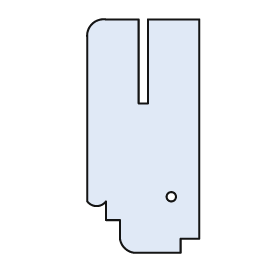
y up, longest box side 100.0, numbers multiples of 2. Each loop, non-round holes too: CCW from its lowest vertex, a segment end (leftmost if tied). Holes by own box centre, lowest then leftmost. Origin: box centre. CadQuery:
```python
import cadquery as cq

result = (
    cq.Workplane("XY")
    .moveTo(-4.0, -50.0)
    .lineTo(16.0, -50.0)
    .lineTo(16.0, -44.0)
    .lineTo(24.0, -44.0)
    .lineTo(24.0, 50.0)
    .lineTo(2.0, 50.0)
    .lineTo(2.0, 14.0)
    .lineTo(-2.0, 14.0)
    .lineTo(-2.0, 50.0)
    .lineTo(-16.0, 50.0)
    .threePointArc((-22.0, 48.0), (-24.0, 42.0))
    .lineTo(-24.0, -28.0)
    .threePointArc((-20.0, -30.0), (-16.0, -28.0))
    .lineTo(-16.0, -36.0)
    .lineTo(-10.0, -36.0)
    .lineTo(-10.0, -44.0)
    .threePointArc((-8.0, -48.0), (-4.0, -50.0))
    .close()
    .moveTo(12.0, -26.0)
    .circle(2.0)
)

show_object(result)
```